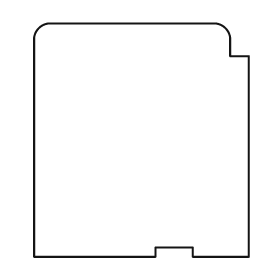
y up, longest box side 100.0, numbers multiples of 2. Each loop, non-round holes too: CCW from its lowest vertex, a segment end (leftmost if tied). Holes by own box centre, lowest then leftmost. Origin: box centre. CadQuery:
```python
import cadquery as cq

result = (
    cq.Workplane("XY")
    .moveTo(-46.0, -50.0)
    .lineTo(6.0, -50.0)
    .lineTo(6.0, -46.0)
    .lineTo(22.0, -46.0)
    .lineTo(22.0, -50.0)
    .lineTo(46.0, -50.0)
    .lineTo(46.0, 36.0)
    .lineTo(38.0, 36.0)
    .lineTo(38.0, 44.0)
    .threePointArc((36.0, 48.0), (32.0, 50.0))
    .lineTo(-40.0, 50.0)
    .threePointArc((-44.0, 48.0), (-46.0, 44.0))
    .close()
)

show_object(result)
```